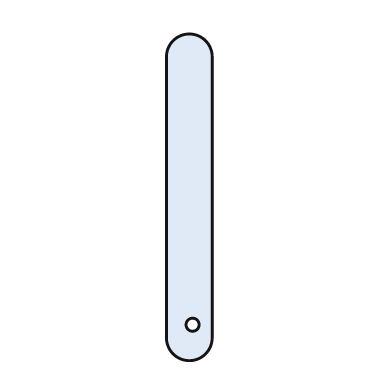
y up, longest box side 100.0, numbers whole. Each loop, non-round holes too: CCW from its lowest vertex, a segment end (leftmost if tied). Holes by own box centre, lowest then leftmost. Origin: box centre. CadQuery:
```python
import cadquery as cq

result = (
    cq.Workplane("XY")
    .moveTo(-7.0, -43.0)
    .threePointArc((0.0, -50.0), (7.0, -43.0))
    .lineTo(7.0, 43.0)
    .threePointArc((0.0, 50.0), (-7.0, 43.0))
    .close()
    .moveTo(1.0, -39.0)
    .circle(2.0)
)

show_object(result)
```